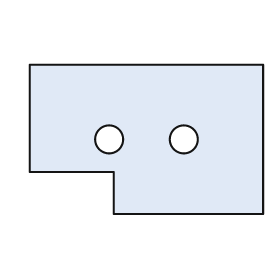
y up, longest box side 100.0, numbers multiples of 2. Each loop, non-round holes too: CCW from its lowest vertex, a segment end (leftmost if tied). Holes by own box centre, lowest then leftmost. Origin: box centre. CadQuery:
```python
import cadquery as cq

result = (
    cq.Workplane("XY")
    .moveTo(-14.0, -32.0)
    .lineTo(50.0, -32.0)
    .lineTo(50.0, 32.0)
    .lineTo(-50.0, 32.0)
    .lineTo(-50.0, -14.0)
    .lineTo(-14.0, -14.0)
    .close()
    .moveTo(-16.0, 0.0)
    .circle(6.0)
    .moveTo(16.0, 0.0)
    .circle(6.0)
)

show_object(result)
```